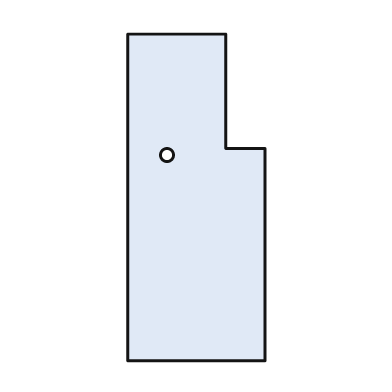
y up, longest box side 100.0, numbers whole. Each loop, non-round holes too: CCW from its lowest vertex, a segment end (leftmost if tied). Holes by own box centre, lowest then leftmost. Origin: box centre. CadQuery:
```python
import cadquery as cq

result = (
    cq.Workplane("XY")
    .moveTo(-21.0, -50.0)
    .lineTo(21.0, -50.0)
    .lineTo(21.0, 15.0)
    .lineTo(9.0, 15.0)
    .lineTo(9.0, 50.0)
    .lineTo(-21.0, 50.0)
    .close()
    .moveTo(-9.0, 13.0)
    .circle(2.0)
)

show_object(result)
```